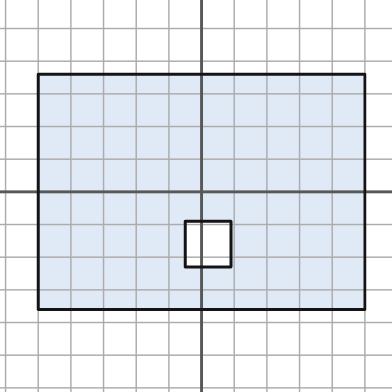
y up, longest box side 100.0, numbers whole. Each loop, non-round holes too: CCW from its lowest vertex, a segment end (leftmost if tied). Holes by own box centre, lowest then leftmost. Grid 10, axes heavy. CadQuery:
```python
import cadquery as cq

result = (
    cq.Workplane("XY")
    .moveTo(-50.0, -36.0)
    .lineTo(50.0, -36.0)
    .lineTo(50.0, 36.0)
    .lineTo(-50.0, 36.0)
    .close()
    .moveTo(-5.0, -23.0)
    .lineTo(9.0, -23.0)
    .lineTo(9.0, -9.0)
    .lineTo(-5.0, -9.0)
    .close()
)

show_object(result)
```